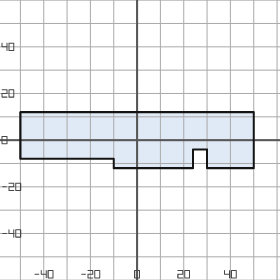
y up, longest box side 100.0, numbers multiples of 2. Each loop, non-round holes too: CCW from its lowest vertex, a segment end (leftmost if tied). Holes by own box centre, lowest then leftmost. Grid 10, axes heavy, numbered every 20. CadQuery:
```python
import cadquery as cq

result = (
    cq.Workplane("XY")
    .moveTo(-10.0, -12.0)
    .lineTo(24.0, -12.0)
    .lineTo(24.0, -4.0)
    .lineTo(30.0, -4.0)
    .lineTo(30.0, -12.0)
    .lineTo(50.0, -12.0)
    .lineTo(50.0, 12.0)
    .lineTo(-50.0, 12.0)
    .lineTo(-50.0, -8.0)
    .lineTo(-10.0, -8.0)
    .close()
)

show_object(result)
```